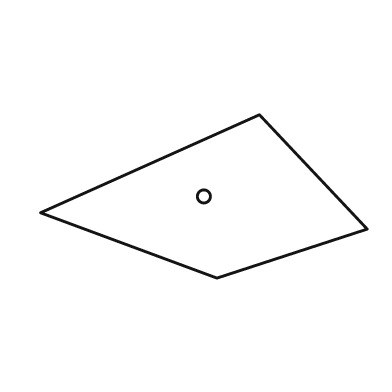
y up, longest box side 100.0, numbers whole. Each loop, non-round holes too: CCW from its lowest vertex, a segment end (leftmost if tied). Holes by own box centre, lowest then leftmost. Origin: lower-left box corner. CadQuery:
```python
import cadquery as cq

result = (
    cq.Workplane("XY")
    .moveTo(54.0, 0.0)
    .lineTo(100.0, 15.0)
    .lineTo(67.0, 50.0)
    .lineTo(0.0, 20.0)
    .close()
    .moveTo(50.0, 25.0)
    .circle(2.0)
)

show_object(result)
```